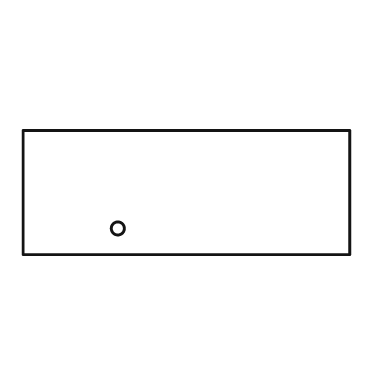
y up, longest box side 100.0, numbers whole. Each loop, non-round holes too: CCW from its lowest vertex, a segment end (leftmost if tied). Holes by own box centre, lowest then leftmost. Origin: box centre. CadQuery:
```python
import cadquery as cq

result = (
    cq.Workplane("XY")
    .moveTo(-50.0, -19.0)
    .lineTo(50.0, -19.0)
    .lineTo(50.0, 19.0)
    .lineTo(-50.0, 19.0)
    .close()
    .moveTo(-21.0, -11.0)
    .circle(2.0)
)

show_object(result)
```